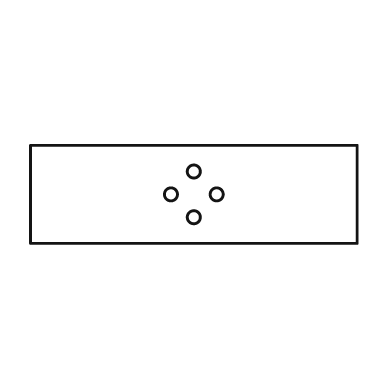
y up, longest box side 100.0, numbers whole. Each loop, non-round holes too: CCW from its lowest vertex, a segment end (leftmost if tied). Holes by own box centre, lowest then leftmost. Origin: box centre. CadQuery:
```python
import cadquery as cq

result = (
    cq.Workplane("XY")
    .moveTo(-50.0, -15.0)
    .lineTo(50.0, -15.0)
    .lineTo(50.0, 15.0)
    .lineTo(-50.0, 15.0)
    .close()
    .moveTo(0.0, -7.0)
    .circle(2.0)
    .moveTo(-7.0, 0.0)
    .circle(2.0)
    .moveTo(7.0, 0.0)
    .circle(2.0)
    .moveTo(0.0, 7.0)
    .circle(2.0)
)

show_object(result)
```